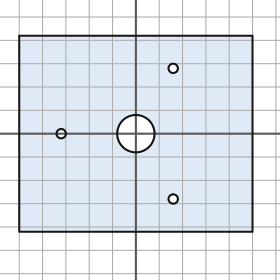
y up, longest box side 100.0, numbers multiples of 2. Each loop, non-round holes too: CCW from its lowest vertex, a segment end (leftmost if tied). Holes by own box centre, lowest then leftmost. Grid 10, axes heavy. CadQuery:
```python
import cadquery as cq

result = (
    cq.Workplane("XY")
    .moveTo(-50.0, -42.0)
    .lineTo(50.0, -42.0)
    .lineTo(50.0, 42.0)
    .lineTo(-50.0, 42.0)
    .close()
    .moveTo(16.0, -28.0)
    .circle(2.0)
    .moveTo(-32.0, 0.0)
    .circle(2.0)
    .moveTo(0.0, 0.0)
    .circle(8.0)
    .moveTo(16.0, 28.0)
    .circle(2.0)
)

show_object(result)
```